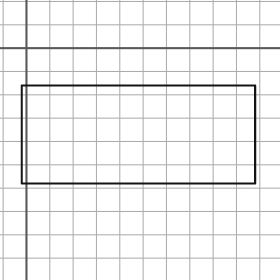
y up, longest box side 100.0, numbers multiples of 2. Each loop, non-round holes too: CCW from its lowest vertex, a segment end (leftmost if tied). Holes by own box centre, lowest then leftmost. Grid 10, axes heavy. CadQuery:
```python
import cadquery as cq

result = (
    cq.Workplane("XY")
    .moveTo(-2.0, -58.0)
    .lineTo(98.0, -58.0)
    .lineTo(98.0, -16.0)
    .lineTo(-2.0, -16.0)
    .close()
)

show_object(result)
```